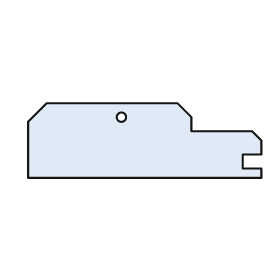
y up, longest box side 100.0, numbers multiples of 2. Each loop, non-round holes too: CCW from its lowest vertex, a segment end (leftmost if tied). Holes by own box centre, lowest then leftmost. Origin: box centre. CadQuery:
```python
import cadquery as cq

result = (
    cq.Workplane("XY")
    .moveTo(-50.0, -16.0)
    .lineTo(50.0, -16.0)
    .lineTo(50.0, -12.0)
    .lineTo(42.0, -12.0)
    .lineTo(42.0, -6.0)
    .lineTo(50.0, -6.0)
    .lineTo(50.0, 0.0)
    .lineTo(46.0, 4.0)
    .lineTo(20.0, 4.0)
    .lineTo(20.0, 10.0)
    .lineTo(14.0, 16.0)
    .lineTo(-42.0, 16.0)
    .lineTo(-50.0, 8.0)
    .close()
    .moveTo(-10.0, 10.0)
    .circle(2.0)
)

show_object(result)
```